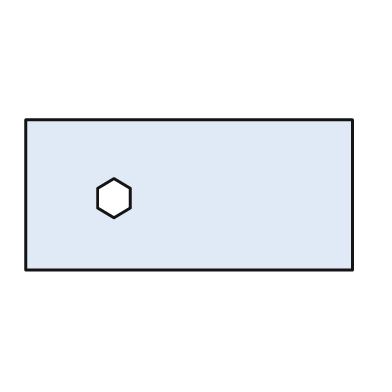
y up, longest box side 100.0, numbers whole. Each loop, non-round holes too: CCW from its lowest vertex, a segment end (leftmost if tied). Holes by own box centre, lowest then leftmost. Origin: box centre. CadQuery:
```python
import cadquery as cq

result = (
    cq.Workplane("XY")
    .moveTo(-50.0, -23.0)
    .lineTo(50.0, -23.0)
    .lineTo(50.0, 23.0)
    .lineTo(-50.0, 23.0)
    .close()
    .moveTo(-23.0, -7.0)
    .lineTo(-18.0, -4.0)
    .lineTo(-18.0, 2.0)
    .lineTo(-23.0, 5.0)
    .lineTo(-28.0, 2.0)
    .lineTo(-28.0, -4.0)
    .close()
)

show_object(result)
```